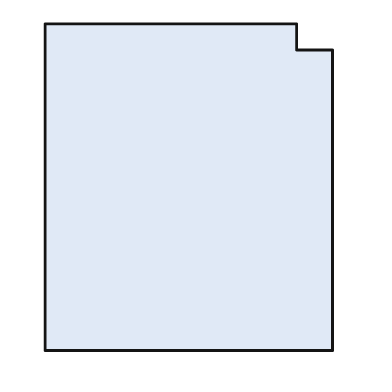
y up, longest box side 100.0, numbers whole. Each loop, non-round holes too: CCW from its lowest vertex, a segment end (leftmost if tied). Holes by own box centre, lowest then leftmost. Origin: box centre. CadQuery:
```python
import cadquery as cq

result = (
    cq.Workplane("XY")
    .moveTo(-44.0, -50.0)
    .lineTo(44.0, -50.0)
    .lineTo(44.0, 42.0)
    .lineTo(33.0, 42.0)
    .lineTo(33.0, 50.0)
    .lineTo(-44.0, 50.0)
    .close()
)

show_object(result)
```